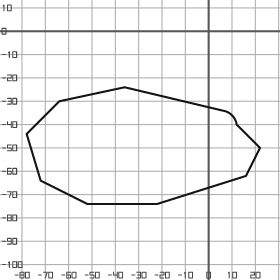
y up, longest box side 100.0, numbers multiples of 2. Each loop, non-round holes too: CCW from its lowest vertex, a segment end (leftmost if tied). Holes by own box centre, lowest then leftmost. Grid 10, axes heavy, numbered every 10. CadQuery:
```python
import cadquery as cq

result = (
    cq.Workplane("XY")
    .moveTo(-52.0, -74.0)
    .lineTo(-22.0, -74.0)
    .lineTo(16.0, -62.0)
    .lineTo(22.0, -50.0)
    .lineTo(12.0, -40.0)
    .threePointArc((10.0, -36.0), (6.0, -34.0))
    .lineTo(-36.0, -24.0)
    .lineTo(-64.0, -30.0)
    .lineTo(-78.0, -44.0)
    .lineTo(-72.0, -64.0)
    .close()
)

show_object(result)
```